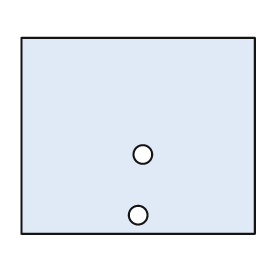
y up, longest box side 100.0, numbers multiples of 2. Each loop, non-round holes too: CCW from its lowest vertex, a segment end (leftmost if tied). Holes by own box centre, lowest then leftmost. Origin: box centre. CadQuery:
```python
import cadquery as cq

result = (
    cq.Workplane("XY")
    .moveTo(-50.0, -42.0)
    .lineTo(50.0, -42.0)
    .lineTo(50.0, 42.0)
    .lineTo(-50.0, 42.0)
    .close()
    .moveTo(0.0, -34.0)
    .circle(4.0)
    .moveTo(2.0, -8.0)
    .circle(4.0)
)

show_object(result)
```